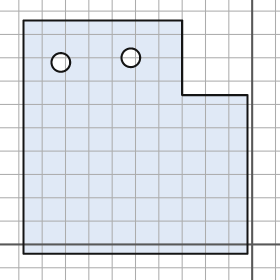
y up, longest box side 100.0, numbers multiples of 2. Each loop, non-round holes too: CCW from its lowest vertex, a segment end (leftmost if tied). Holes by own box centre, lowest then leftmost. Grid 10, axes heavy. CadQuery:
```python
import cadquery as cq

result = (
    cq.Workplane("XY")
    .moveTo(-98.0, -4.0)
    .lineTo(-2.0, -4.0)
    .lineTo(-2.0, 64.0)
    .lineTo(-30.0, 64.0)
    .lineTo(-30.0, 96.0)
    .lineTo(-98.0, 96.0)
    .close()
    .moveTo(-82.0, 78.0)
    .circle(4.0)
    .moveTo(-52.0, 80.0)
    .circle(4.0)
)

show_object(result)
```